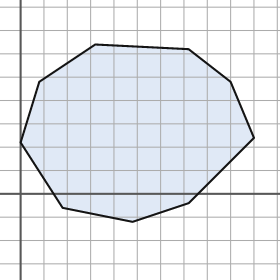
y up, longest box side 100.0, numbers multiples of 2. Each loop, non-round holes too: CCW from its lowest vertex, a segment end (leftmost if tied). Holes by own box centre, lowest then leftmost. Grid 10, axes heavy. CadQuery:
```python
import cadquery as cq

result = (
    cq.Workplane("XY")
    .moveTo(48.0, -12.0)
    .lineTo(72.0, -4.0)
    .lineTo(100.0, 24.0)
    .lineTo(90.0, 48.0)
    .lineTo(72.0, 62.0)
    .lineTo(32.0, 64.0)
    .lineTo(8.0, 48.0)
    .lineTo(0.0, 22.0)
    .lineTo(18.0, -6.0)
    .close()
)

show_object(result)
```